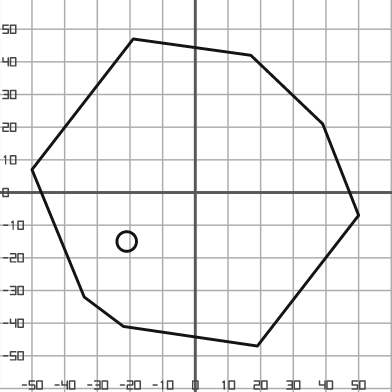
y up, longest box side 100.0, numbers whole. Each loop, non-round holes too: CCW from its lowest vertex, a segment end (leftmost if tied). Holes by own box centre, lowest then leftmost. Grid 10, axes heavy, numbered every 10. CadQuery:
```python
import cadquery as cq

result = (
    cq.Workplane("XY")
    .moveTo(19.0, -47.0)
    .lineTo(50.0, -7.0)
    .lineTo(39.0, 21.0)
    .lineTo(17.0, 42.0)
    .lineTo(-19.0, 47.0)
    .lineTo(-50.0, 7.0)
    .lineTo(-34.0, -32.0)
    .lineTo(-22.0, -41.0)
    .close()
    .moveTo(-21.0, -15.0)
    .circle(3.0)
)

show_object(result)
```